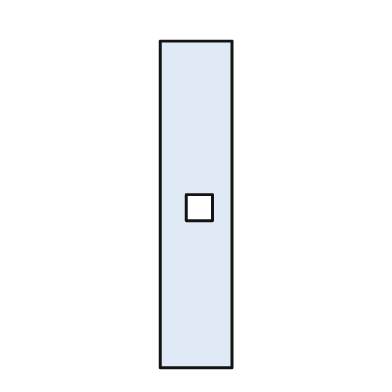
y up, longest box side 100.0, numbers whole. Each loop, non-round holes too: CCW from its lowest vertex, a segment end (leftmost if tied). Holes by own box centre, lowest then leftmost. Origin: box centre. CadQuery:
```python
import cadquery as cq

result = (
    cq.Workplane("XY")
    .moveTo(-11.0, -50.0)
    .lineTo(11.0, -50.0)
    .lineTo(11.0, 50.0)
    .lineTo(-11.0, 50.0)
    .close()
    .moveTo(-3.0, -5.0)
    .lineTo(5.0, -5.0)
    .lineTo(5.0, 3.0)
    .lineTo(-3.0, 3.0)
    .close()
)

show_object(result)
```